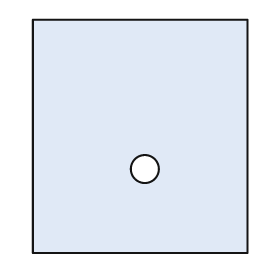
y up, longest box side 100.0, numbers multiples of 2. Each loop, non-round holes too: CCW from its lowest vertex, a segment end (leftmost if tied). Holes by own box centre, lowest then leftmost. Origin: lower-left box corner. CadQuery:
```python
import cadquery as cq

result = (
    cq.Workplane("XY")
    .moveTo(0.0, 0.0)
    .lineTo(92.0, 0.0)
    .lineTo(92.0, 100.0)
    .lineTo(0.0, 100.0)
    .close()
    .moveTo(48.0, 36.0)
    .circle(6.0)
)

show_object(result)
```